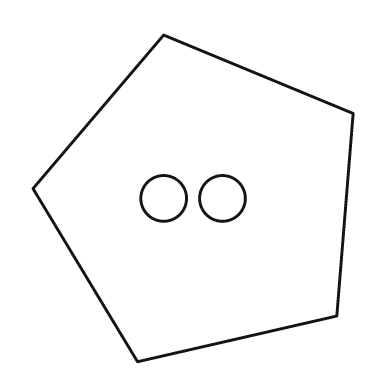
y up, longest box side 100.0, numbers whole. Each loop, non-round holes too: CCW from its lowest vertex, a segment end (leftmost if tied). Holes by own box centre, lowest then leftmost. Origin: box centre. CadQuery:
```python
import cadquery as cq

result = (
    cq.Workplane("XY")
    .moveTo(-17.0, -50.0)
    .lineTo(44.0, -36.0)
    .lineTo(49.0, 26.0)
    .lineTo(-9.0, 50.0)
    .lineTo(-49.0, 3.0)
    .close()
    .moveTo(-9.0, 0.0)
    .circle(7.0)
    .moveTo(9.0, 0.0)
    .circle(7.0)
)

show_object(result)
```